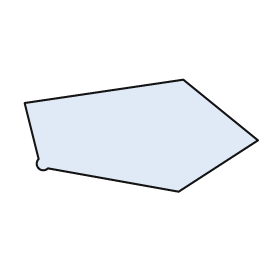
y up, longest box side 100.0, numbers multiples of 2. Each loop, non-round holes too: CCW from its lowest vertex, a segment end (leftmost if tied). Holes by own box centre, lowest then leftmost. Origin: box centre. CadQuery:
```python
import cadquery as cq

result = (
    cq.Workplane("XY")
    .moveTo(16.0, -24.0)
    .lineTo(50.0, -2.0)
    .lineTo(18.0, 24.0)
    .lineTo(-50.0, 14.0)
    .lineTo(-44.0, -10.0)
    .threePointArc((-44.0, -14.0), (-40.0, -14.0))
    .close()
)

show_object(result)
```